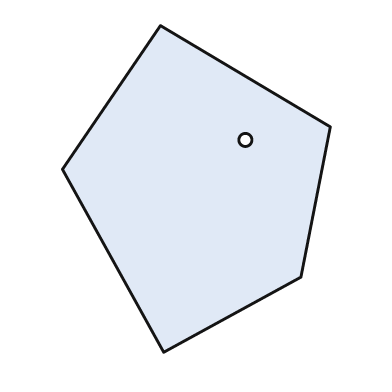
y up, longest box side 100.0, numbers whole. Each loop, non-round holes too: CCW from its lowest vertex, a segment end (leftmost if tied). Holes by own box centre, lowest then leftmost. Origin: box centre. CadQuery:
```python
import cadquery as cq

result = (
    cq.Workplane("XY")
    .moveTo(-10.0, -50.0)
    .lineTo(32.0, -27.0)
    .lineTo(41.0, 19.0)
    .lineTo(-11.0, 50.0)
    .lineTo(-41.0, 6.0)
    .close()
    .moveTo(15.0, 15.0)
    .circle(2.0)
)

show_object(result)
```